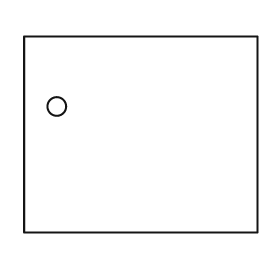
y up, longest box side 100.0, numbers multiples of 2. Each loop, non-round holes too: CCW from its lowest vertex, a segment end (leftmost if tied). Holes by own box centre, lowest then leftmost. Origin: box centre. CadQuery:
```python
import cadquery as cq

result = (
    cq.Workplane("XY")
    .moveTo(-50.0, -42.0)
    .lineTo(50.0, -42.0)
    .lineTo(50.0, 42.0)
    .lineTo(-50.0, 42.0)
    .close()
    .moveTo(-36.0, 12.0)
    .circle(4.0)
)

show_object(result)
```